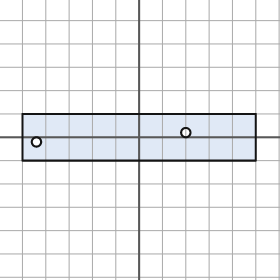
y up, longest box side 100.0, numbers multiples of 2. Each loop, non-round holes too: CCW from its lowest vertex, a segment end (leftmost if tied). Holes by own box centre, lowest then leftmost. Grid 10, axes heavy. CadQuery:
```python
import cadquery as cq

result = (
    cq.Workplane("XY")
    .moveTo(-50.0, -10.0)
    .lineTo(50.0, -10.0)
    .lineTo(50.0, 10.0)
    .lineTo(-50.0, 10.0)
    .close()
    .moveTo(-44.0, -2.0)
    .circle(2.0)
    .moveTo(20.0, 2.0)
    .circle(2.0)
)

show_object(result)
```